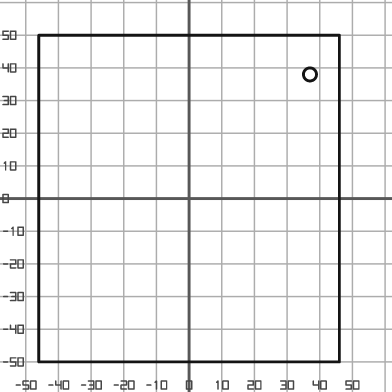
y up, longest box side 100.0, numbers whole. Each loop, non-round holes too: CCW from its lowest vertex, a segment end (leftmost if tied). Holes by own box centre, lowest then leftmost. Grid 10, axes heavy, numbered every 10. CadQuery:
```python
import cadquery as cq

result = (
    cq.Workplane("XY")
    .moveTo(-46.0, -50.0)
    .lineTo(46.0, -50.0)
    .lineTo(46.0, 50.0)
    .lineTo(-46.0, 50.0)
    .close()
    .moveTo(37.0, 38.0)
    .circle(2.0)
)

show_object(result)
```